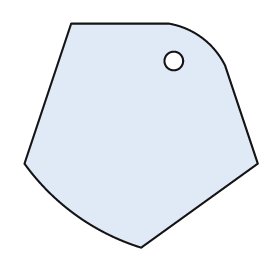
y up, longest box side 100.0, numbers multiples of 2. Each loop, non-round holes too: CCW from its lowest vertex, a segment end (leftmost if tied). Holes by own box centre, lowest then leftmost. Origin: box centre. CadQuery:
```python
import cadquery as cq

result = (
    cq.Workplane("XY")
    .moveTo(0.0, -48.0)
    .lineTo(50.0, -12.0)
    .lineTo(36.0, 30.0)
    .threePointArc((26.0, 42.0), (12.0, 48.0))
    .lineTo(-30.0, 48.0)
    .lineTo(-50.0, -12.0)
    .threePointArc((-28.0, -34.0), (0.0, -48.0))
    .close()
    .moveTo(14.0, 32.0)
    .circle(4.0)
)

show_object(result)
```